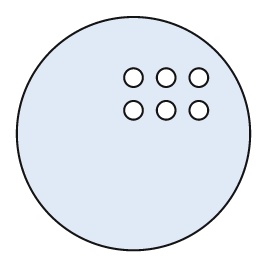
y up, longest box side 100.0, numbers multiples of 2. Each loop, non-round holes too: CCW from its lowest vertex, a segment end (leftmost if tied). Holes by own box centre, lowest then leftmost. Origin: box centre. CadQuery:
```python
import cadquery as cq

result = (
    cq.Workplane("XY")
    .moveTo(0.0, 0.0)
    .circle(50.0)
    .moveTo(0.0, 10.0)
    .circle(4.0)
    .moveTo(14.0, 10.0)
    .circle(4.0)
    .moveTo(28.0, 10.0)
    .circle(4.0)
    .moveTo(0.0, 24.0)
    .circle(4.0)
    .moveTo(14.0, 24.0)
    .circle(4.0)
    .moveTo(28.0, 24.0)
    .circle(4.0)
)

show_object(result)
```